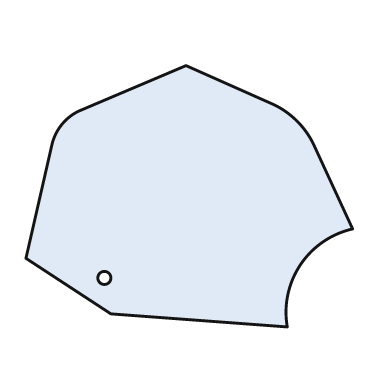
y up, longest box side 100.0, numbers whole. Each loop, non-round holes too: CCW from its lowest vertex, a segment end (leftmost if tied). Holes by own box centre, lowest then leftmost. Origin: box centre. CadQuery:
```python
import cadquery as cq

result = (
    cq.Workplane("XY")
    .moveTo(30.0, -40.0)
    .threePointArc((34.0, -21.0), (50.0, -10.0))
    .lineTo(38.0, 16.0)
    .threePointArc((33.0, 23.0), (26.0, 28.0))
    .lineTo(-1.0, 40.0)
    .lineTo(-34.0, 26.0)
    .threePointArc((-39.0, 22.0), (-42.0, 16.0))
    .lineTo(-50.0, -19.0)
    .lineTo(-24.0, -36.0)
    .close()
    .moveTo(-26.0, -25.0)
    .circle(2.0)
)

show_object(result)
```